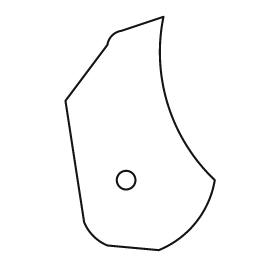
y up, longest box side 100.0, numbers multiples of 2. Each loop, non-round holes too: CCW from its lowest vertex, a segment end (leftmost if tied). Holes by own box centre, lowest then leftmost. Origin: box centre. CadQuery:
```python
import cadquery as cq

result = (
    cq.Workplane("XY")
    .moveTo(8.0, -50.0)
    .threePointArc((24.0, -38.0), (32.0, -20.0))
    .threePointArc((12.0, 12.0), (10.0, 50.0))
    .lineTo(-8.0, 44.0)
    .threePointArc((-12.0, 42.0), (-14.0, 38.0))
    .lineTo(-32.0, 14.0)
    .lineTo(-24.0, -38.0)
    .threePointArc((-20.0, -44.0), (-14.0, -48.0))
    .close()
    .moveTo(-6.0, -20.0)
    .circle(4.0)
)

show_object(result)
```